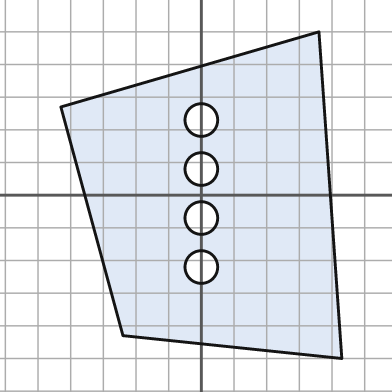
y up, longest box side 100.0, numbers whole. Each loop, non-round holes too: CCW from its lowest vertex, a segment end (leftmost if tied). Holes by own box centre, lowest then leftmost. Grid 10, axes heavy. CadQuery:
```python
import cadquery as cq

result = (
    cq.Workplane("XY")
    .moveTo(43.0, -50.0)
    .lineTo(36.0, 50.0)
    .lineTo(-43.0, 27.0)
    .lineTo(-24.0, -43.0)
    .close()
    .moveTo(0.0, -22.0)
    .circle(5.0)
    .moveTo(0.0, -7.0)
    .circle(5.0)
    .moveTo(0.0, 8.0)
    .circle(5.0)
    .moveTo(0.0, 23.0)
    .circle(5.0)
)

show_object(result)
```